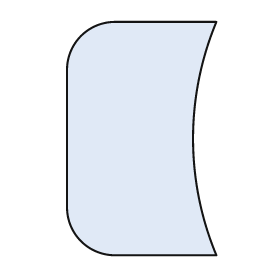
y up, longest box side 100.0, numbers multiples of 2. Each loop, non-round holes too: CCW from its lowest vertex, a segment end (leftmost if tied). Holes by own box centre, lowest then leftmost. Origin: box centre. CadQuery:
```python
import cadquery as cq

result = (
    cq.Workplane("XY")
    .moveTo(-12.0, -50.0)
    .lineTo(32.0, -50.0)
    .threePointArc((22.0, 0.0), (32.0, 50.0))
    .lineTo(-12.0, 50.0)
    .threePointArc((-26.0, 44.0), (-32.0, 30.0))
    .lineTo(-32.0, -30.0)
    .threePointArc((-26.0, -44.0), (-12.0, -50.0))
    .close()
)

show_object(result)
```